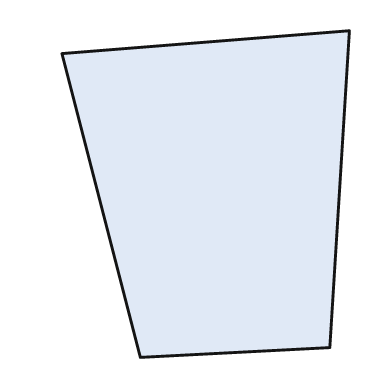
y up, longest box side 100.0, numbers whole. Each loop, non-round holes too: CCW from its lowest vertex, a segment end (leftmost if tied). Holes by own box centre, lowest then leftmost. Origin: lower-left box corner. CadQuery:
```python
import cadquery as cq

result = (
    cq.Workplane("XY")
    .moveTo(24.0, 0.0)
    .lineTo(82.0, 3.0)
    .lineTo(88.0, 100.0)
    .lineTo(0.0, 93.0)
    .close()
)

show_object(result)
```